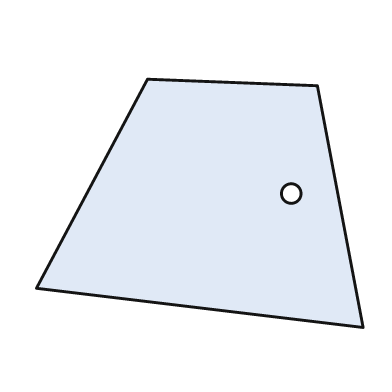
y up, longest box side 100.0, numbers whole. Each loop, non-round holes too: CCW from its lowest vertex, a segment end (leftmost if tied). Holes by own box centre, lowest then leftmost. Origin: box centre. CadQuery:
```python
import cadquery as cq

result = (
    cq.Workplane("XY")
    .moveTo(50.0, -38.0)
    .lineTo(36.0, 36.0)
    .lineTo(-16.0, 38.0)
    .lineTo(-50.0, -26.0)
    .close()
    .moveTo(28.0, 3.0)
    .circle(3.0)
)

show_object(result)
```